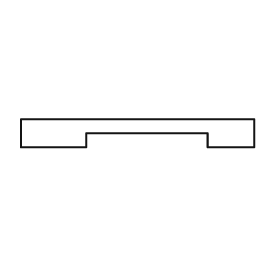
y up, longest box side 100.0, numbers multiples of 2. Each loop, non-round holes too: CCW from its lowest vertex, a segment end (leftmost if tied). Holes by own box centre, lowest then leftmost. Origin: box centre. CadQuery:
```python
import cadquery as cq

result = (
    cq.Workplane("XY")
    .moveTo(-50.0, -6.0)
    .lineTo(-22.0, -6.0)
    .lineTo(-22.0, 0.0)
    .lineTo(30.0, 0.0)
    .lineTo(30.0, -6.0)
    .lineTo(50.0, -6.0)
    .lineTo(50.0, 6.0)
    .lineTo(-50.0, 6.0)
    .close()
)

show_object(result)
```